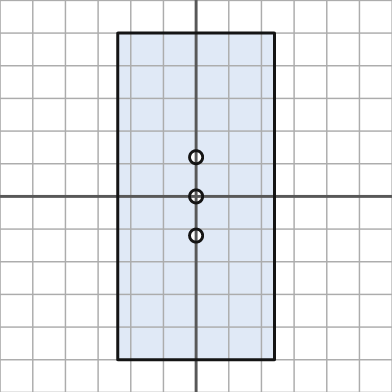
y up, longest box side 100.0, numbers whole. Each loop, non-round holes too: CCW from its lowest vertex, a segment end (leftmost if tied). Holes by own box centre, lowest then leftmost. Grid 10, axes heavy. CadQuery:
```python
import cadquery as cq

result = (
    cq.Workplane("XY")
    .moveTo(-24.0, -50.0)
    .lineTo(24.0, -50.0)
    .lineTo(24.0, 50.0)
    .lineTo(-24.0, 50.0)
    .close()
    .moveTo(0.0, -12.0)
    .circle(2.0)
    .moveTo(0.0, 0.0)
    .circle(2.0)
    .moveTo(0.0, 12.0)
    .circle(2.0)
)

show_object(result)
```